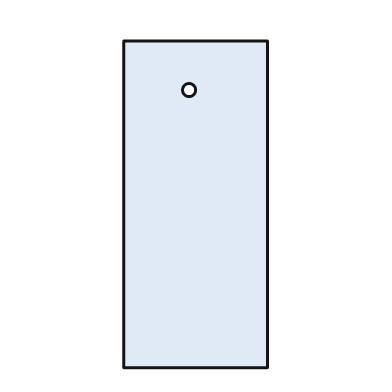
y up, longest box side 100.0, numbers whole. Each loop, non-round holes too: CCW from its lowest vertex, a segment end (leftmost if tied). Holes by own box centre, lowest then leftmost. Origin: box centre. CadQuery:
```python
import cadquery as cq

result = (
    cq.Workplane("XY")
    .moveTo(-22.0, -50.0)
    .lineTo(22.0, -50.0)
    .lineTo(22.0, 50.0)
    .lineTo(-22.0, 50.0)
    .close()
    .moveTo(-2.0, 35.0)
    .circle(2.0)
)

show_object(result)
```